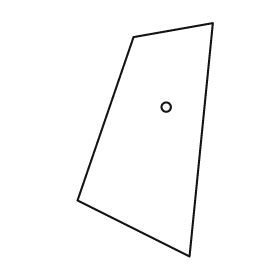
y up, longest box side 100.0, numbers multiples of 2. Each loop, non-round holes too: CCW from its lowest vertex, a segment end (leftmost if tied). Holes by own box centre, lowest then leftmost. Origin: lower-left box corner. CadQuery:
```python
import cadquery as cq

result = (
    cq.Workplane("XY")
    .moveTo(48.0, 0.0)
    .lineTo(58.0, 100.0)
    .lineTo(24.0, 94.0)
    .lineTo(0.0, 24.0)
    .close()
    .moveTo(38.0, 64.0)
    .circle(2.0)
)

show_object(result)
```